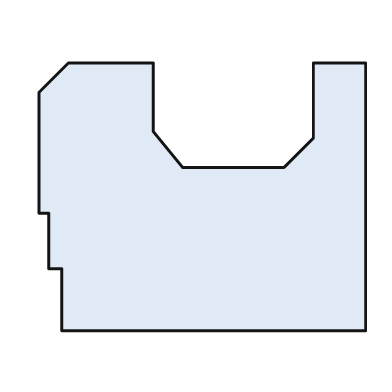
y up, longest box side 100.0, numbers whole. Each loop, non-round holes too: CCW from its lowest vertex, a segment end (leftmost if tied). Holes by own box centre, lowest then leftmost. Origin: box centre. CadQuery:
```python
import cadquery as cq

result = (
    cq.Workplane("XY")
    .moveTo(-43.0, -41.0)
    .lineTo(50.0, -41.0)
    .lineTo(50.0, 41.0)
    .lineTo(34.0, 41.0)
    .lineTo(34.0, 18.0)
    .lineTo(25.0, 9.0)
    .lineTo(-6.0, 9.0)
    .lineTo(-15.0, 20.0)
    .lineTo(-15.0, 41.0)
    .lineTo(-41.0, 41.0)
    .lineTo(-50.0, 32.0)
    .lineTo(-50.0, -5.0)
    .lineTo(-47.0, -5.0)
    .lineTo(-47.0, -22.0)
    .lineTo(-43.0, -22.0)
    .close()
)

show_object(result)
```